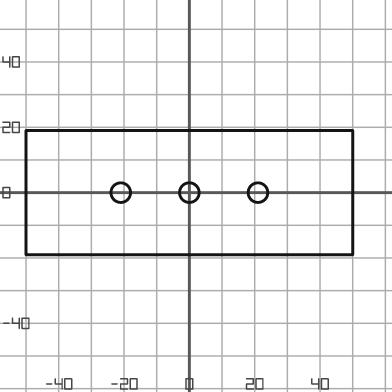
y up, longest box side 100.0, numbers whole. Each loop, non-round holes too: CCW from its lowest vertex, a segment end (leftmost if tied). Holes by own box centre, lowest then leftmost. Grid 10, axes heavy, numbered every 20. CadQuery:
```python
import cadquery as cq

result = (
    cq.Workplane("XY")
    .moveTo(-50.0, -19.0)
    .lineTo(50.0, -19.0)
    .lineTo(50.0, 19.0)
    .lineTo(-50.0, 19.0)
    .close()
    .moveTo(-21.0, 0.0)
    .circle(3.0)
    .moveTo(0.0, 0.0)
    .circle(3.0)
    .moveTo(21.0, 0.0)
    .circle(3.0)
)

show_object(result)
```